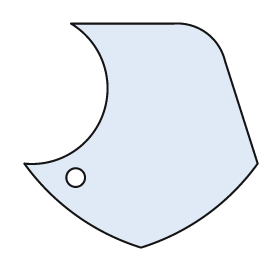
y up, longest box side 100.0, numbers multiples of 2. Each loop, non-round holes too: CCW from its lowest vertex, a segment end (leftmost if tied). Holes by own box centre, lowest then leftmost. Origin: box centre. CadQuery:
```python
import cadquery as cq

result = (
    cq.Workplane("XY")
    .moveTo(0.0, -48.0)
    .threePointArc((28.0, -34.0), (50.0, -12.0))
    .lineTo(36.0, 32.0)
    .threePointArc((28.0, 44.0), (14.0, 48.0))
    .lineTo(-30.0, 48.0)
    .threePointArc((-16.0, 10.0), (-50.0, -12.0))
    .threePointArc((-28.0, -34.0), (0.0, -48.0))
    .close()
    .moveTo(-28.0, -18.0)
    .circle(4.0)
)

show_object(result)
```